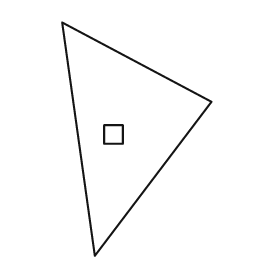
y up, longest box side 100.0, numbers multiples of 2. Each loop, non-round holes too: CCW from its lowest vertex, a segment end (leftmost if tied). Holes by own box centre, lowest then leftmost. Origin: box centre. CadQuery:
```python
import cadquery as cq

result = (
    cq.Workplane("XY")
    .moveTo(-18.0, -50.0)
    .lineTo(32.0, 16.0)
    .lineTo(-32.0, 50.0)
    .close()
    .moveTo(-14.0, -2.0)
    .lineTo(-6.0, -2.0)
    .lineTo(-6.0, 6.0)
    .lineTo(-14.0, 6.0)
    .close()
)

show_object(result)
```